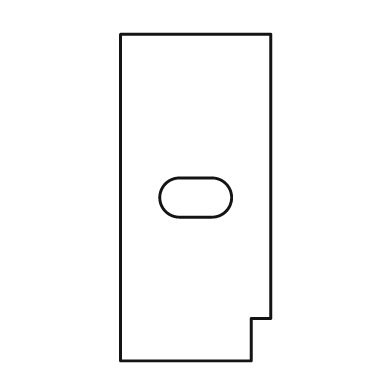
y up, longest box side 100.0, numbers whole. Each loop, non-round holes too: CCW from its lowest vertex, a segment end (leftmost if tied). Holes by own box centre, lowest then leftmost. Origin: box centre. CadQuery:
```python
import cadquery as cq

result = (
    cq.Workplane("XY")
    .moveTo(-23.0, -50.0)
    .lineTo(17.0, -50.0)
    .lineTo(17.0, -37.0)
    .lineTo(23.0, -37.0)
    .lineTo(23.0, 50.0)
    .lineTo(-23.0, 50.0)
    .close()
    .moveTo(-5.0, -6.0)
    .lineTo(5.0, -6.0)
    .threePointArc((11.0, 0.0), (5.0, 6.0))
    .lineTo(-5.0, 6.0)
    .threePointArc((-11.0, 0.0), (-5.0, -6.0))
    .close()
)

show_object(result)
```